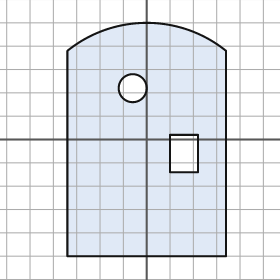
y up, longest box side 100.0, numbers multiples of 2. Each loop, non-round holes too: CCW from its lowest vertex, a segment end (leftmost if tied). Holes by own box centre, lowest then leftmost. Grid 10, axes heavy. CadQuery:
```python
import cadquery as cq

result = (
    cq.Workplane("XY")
    .moveTo(-34.0, -50.0)
    .lineTo(34.0, -50.0)
    .lineTo(34.0, 38.0)
    .threePointArc((0.0, 50.0), (-34.0, 38.0))
    .close()
    .moveTo(10.0, -14.0)
    .lineTo(22.0, -14.0)
    .lineTo(22.0, 2.0)
    .lineTo(10.0, 2.0)
    .close()
    .moveTo(-6.0, 22.0)
    .circle(6.0)
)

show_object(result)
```